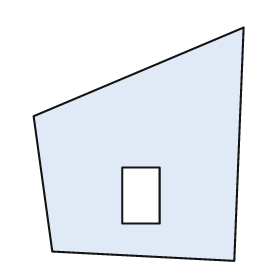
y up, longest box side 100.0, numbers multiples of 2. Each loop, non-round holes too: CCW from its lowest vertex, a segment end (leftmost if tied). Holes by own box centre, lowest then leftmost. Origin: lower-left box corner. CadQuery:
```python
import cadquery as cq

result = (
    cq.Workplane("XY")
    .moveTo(86.0, 0.0)
    .lineTo(90.0, 100.0)
    .lineTo(0.0, 62.0)
    .lineTo(8.0, 4.0)
    .close()
    .moveTo(38.0, 16.0)
    .lineTo(54.0, 16.0)
    .lineTo(54.0, 40.0)
    .lineTo(38.0, 40.0)
    .close()
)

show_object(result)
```